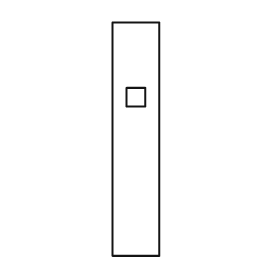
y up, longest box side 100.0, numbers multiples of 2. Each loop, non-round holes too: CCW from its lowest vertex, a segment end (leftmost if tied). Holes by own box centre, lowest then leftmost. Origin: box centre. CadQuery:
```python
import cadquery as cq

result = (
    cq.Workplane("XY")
    .moveTo(-10.0, -50.0)
    .lineTo(10.0, -50.0)
    .lineTo(10.0, 50.0)
    .lineTo(-10.0, 50.0)
    .close()
    .moveTo(-4.0, 14.0)
    .lineTo(4.0, 14.0)
    .lineTo(4.0, 22.0)
    .lineTo(-4.0, 22.0)
    .close()
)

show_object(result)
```